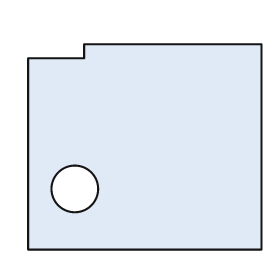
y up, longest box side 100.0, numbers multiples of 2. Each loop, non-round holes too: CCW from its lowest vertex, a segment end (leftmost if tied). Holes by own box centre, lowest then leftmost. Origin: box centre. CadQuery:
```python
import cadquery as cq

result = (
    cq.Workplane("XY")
    .moveTo(-50.0, -44.0)
    .lineTo(50.0, -44.0)
    .lineTo(50.0, 44.0)
    .lineTo(-26.0, 44.0)
    .lineTo(-26.0, 38.0)
    .lineTo(-50.0, 38.0)
    .close()
    .moveTo(-30.0, -18.0)
    .circle(10.0)
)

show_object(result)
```